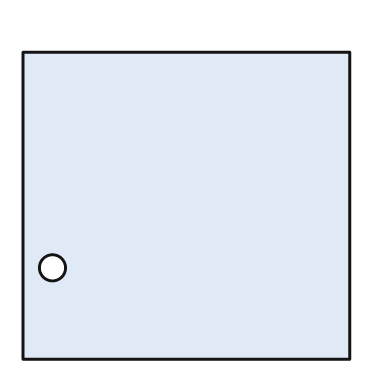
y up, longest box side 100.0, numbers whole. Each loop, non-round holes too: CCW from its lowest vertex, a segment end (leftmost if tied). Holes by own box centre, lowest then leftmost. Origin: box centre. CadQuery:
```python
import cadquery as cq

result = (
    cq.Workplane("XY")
    .moveTo(-50.0, -47.0)
    .lineTo(50.0, -47.0)
    .lineTo(50.0, 47.0)
    .lineTo(-50.0, 47.0)
    .close()
    .moveTo(-41.0, -19.0)
    .circle(4.0)
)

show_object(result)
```